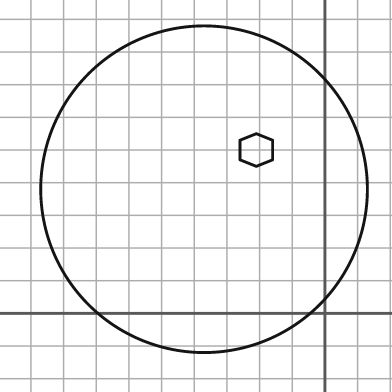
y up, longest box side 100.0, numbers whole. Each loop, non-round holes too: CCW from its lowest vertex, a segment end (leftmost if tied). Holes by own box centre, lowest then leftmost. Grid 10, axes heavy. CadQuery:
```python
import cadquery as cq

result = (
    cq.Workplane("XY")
    .moveTo(-37.0, 38.0)
    .circle(50.0)
    .moveTo(-21.0, 45.0)
    .lineTo(-16.0, 47.0)
    .lineTo(-16.0, 53.0)
    .lineTo(-21.0, 55.0)
    .lineTo(-26.0, 53.0)
    .lineTo(-26.0, 47.0)
    .close()
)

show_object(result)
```